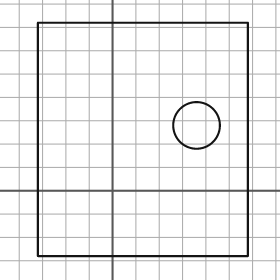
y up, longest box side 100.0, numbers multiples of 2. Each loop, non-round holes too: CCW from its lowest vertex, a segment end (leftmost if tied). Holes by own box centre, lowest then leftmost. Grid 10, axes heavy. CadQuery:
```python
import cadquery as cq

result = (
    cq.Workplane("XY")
    .moveTo(-32.0, -28.0)
    .lineTo(58.0, -28.0)
    .lineTo(58.0, 72.0)
    .lineTo(-32.0, 72.0)
    .close()
    .moveTo(36.0, 28.0)
    .circle(10.0)
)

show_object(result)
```